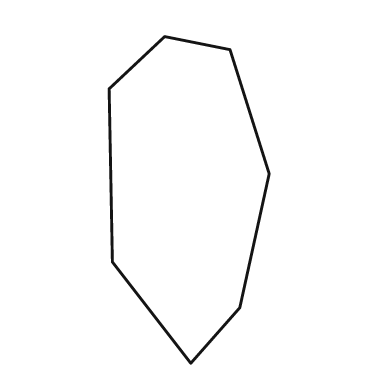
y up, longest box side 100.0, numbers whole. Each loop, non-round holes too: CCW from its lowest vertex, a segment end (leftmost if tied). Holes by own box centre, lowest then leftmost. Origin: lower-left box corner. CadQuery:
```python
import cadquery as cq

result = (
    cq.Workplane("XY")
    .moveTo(25.0, 0.0)
    .lineTo(40.0, 17.0)
    .lineTo(49.0, 58.0)
    .lineTo(37.0, 96.0)
    .lineTo(17.0, 100.0)
    .lineTo(0.0, 84.0)
    .lineTo(1.0, 31.0)
    .close()
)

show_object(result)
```